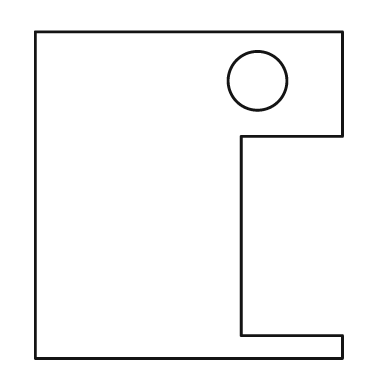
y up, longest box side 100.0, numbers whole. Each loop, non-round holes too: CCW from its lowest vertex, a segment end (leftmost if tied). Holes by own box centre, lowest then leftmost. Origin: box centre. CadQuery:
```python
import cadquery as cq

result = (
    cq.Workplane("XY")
    .moveTo(-47.0, -50.0)
    .lineTo(47.0, -50.0)
    .lineTo(47.0, -43.0)
    .lineTo(16.0, -43.0)
    .lineTo(16.0, 18.0)
    .lineTo(47.0, 18.0)
    .lineTo(47.0, 50.0)
    .lineTo(-47.0, 50.0)
    .close()
    .moveTo(21.0, 35.0)
    .circle(9.0)
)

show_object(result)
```